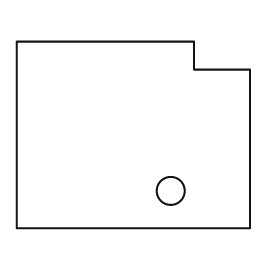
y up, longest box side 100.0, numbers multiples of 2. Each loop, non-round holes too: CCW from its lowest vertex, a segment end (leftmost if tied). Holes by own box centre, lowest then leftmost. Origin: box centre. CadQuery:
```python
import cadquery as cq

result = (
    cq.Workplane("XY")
    .moveTo(-50.0, -40.0)
    .lineTo(50.0, -40.0)
    .lineTo(50.0, 28.0)
    .lineTo(26.0, 28.0)
    .lineTo(26.0, 40.0)
    .lineTo(-50.0, 40.0)
    .close()
    .moveTo(16.0, -24.0)
    .circle(6.0)
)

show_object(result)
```